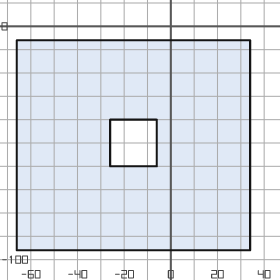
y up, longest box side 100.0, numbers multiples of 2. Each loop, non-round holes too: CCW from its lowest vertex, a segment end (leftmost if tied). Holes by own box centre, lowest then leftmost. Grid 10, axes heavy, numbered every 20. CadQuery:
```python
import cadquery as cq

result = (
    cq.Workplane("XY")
    .moveTo(-66.0, -96.0)
    .lineTo(34.0, -96.0)
    .lineTo(34.0, -6.0)
    .lineTo(-66.0, -6.0)
    .close()
    .moveTo(-26.0, -60.0)
    .lineTo(-6.0, -60.0)
    .lineTo(-6.0, -40.0)
    .lineTo(-26.0, -40.0)
    .close()
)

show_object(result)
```